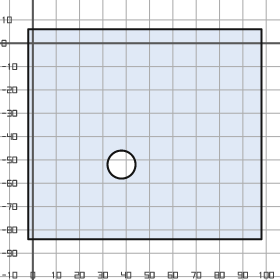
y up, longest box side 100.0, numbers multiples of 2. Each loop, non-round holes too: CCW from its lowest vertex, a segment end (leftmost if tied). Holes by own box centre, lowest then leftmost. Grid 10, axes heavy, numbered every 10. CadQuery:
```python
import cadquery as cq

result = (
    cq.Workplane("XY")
    .moveTo(-2.0, -84.0)
    .lineTo(98.0, -84.0)
    .lineTo(98.0, 6.0)
    .lineTo(-2.0, 6.0)
    .close()
    .moveTo(38.0, -52.0)
    .circle(6.0)
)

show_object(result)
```